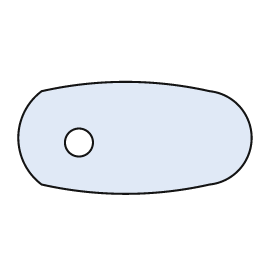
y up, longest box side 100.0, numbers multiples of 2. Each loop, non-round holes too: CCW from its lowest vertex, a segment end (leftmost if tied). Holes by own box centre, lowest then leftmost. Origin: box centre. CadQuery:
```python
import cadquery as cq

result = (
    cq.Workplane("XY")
    .moveTo(-40.0, -20.0)
    .threePointArc((-4.0, -24.0), (32.0, -20.0))
    .threePointArc((50.0, 0.0), (32.0, 20.0))
    .threePointArc((-4.0, 24.0), (-40.0, 20.0))
    .threePointArc((-50.0, 0.0), (-40.0, -20.0))
    .close()
    .moveTo(-24.0, -2.0)
    .circle(6.0)
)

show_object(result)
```